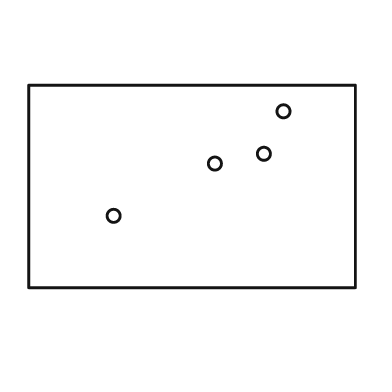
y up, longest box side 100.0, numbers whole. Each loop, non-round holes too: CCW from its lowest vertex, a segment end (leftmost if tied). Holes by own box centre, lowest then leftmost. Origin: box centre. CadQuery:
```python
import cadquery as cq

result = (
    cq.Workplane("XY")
    .moveTo(-50.0, -31.0)
    .lineTo(50.0, -31.0)
    .lineTo(50.0, 31.0)
    .lineTo(-50.0, 31.0)
    .close()
    .moveTo(-24.0, -9.0)
    .circle(2.0)
    .moveTo(7.0, 7.0)
    .circle(2.0)
    .moveTo(22.0, 10.0)
    .circle(2.0)
    .moveTo(28.0, 23.0)
    .circle(2.0)
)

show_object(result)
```